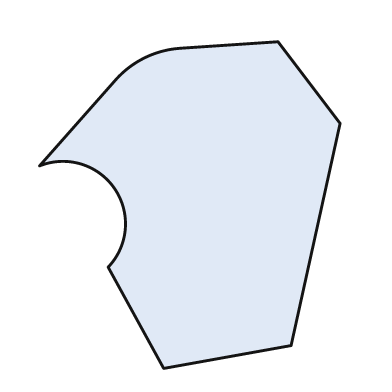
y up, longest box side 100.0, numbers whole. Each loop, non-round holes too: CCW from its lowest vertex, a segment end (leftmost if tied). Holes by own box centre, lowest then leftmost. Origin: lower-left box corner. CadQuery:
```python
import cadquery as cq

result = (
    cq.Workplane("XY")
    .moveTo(38.0, 0.0)
    .lineTo(77.0, 7.0)
    .lineTo(92.0, 75.0)
    .lineTo(73.0, 100.0)
    .lineTo(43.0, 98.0)
    .threePointArc((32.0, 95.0), (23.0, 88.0))
    .lineTo(0.0, 62.0)
    .threePointArc((23.0, 55.0), (21.0, 31.0))
    .close()
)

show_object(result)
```